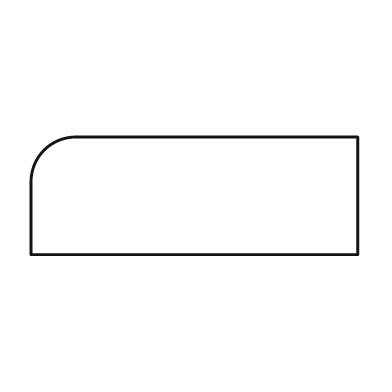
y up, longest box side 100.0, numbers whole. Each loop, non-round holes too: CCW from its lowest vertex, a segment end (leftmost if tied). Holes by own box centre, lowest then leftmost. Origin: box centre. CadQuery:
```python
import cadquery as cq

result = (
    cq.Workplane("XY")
    .moveTo(-50.0, -18.0)
    .lineTo(50.0, -18.0)
    .lineTo(50.0, 18.0)
    .lineTo(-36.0, 18.0)
    .threePointArc((-46.0, 14.0), (-50.0, 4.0))
    .close()
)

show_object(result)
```